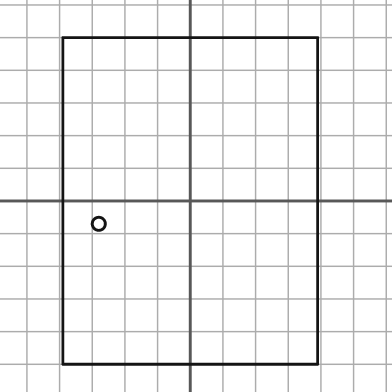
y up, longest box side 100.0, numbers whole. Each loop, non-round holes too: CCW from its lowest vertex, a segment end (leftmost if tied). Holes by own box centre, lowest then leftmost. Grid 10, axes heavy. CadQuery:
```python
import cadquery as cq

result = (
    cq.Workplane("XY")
    .moveTo(-39.0, -50.0)
    .lineTo(39.0, -50.0)
    .lineTo(39.0, 50.0)
    .lineTo(-39.0, 50.0)
    .close()
    .moveTo(-28.0, -7.0)
    .circle(2.0)
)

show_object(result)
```